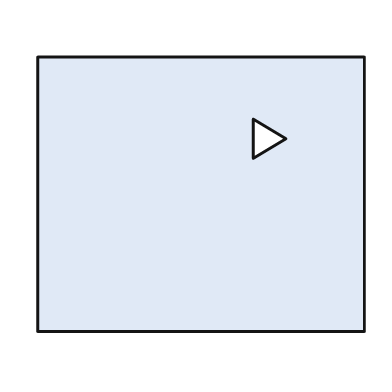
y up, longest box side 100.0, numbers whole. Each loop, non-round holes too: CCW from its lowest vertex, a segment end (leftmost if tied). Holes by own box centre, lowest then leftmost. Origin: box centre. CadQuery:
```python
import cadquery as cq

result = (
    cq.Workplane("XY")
    .moveTo(-50.0, -42.0)
    .lineTo(50.0, -42.0)
    .lineTo(50.0, 42.0)
    .lineTo(-50.0, 42.0)
    .close()
    .moveTo(16.0, 11.0)
    .lineTo(26.0, 17.0)
    .lineTo(16.0, 23.0)
    .close()
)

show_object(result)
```